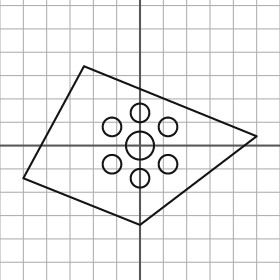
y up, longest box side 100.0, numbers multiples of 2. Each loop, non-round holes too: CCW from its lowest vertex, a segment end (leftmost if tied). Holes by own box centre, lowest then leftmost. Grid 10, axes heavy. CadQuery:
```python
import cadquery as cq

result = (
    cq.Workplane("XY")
    .moveTo(0.0, -34.0)
    .lineTo(50.0, 4.0)
    .lineTo(-24.0, 34.0)
    .lineTo(-50.0, -14.0)
    .close()
    .moveTo(0.0, -14.0)
    .circle(4.0)
    .moveTo(-12.0, -8.0)
    .circle(4.0)
    .moveTo(12.0, -8.0)
    .circle(4.0)
    .moveTo(0.0, 0.0)
    .circle(6.0)
    .moveTo(-12.0, 8.0)
    .circle(4.0)
    .moveTo(12.0, 8.0)
    .circle(4.0)
    .moveTo(0.0, 14.0)
    .circle(4.0)
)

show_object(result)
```